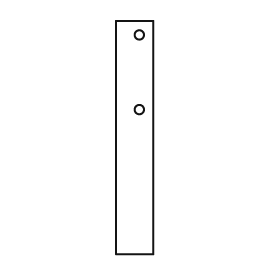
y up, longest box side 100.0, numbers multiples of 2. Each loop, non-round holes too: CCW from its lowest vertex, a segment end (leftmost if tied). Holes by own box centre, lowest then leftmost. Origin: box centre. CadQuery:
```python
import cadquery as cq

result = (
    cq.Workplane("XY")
    .moveTo(-8.0, -50.0)
    .lineTo(8.0, -50.0)
    .lineTo(8.0, 50.0)
    .lineTo(-8.0, 50.0)
    .close()
    .moveTo(2.0, 12.0)
    .circle(2.0)
    .moveTo(2.0, 44.0)
    .circle(2.0)
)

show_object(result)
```